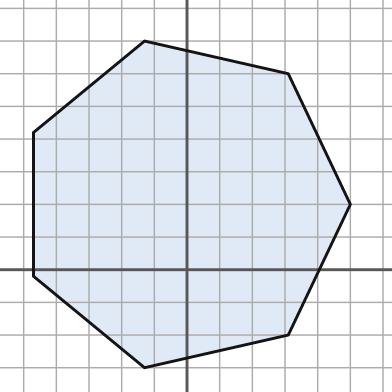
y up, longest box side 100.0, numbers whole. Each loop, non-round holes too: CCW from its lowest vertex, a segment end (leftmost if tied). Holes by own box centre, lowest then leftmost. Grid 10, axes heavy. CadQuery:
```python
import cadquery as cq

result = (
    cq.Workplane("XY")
    .moveTo(-13.0, -30.0)
    .lineTo(31.0, -20.0)
    .lineTo(50.0, 20.0)
    .lineTo(31.0, 60.0)
    .lineTo(-13.0, 70.0)
    .lineTo(-47.0, 42.0)
    .lineTo(-47.0, -2.0)
    .close()
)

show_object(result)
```